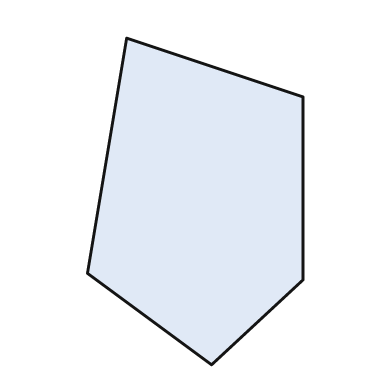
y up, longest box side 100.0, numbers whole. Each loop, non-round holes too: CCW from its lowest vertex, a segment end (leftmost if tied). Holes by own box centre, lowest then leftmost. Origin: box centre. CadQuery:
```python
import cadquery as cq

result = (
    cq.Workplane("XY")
    .moveTo(5.0, -50.0)
    .lineTo(33.0, -24.0)
    .lineTo(33.0, 32.0)
    .lineTo(-21.0, 50.0)
    .lineTo(-33.0, -22.0)
    .close()
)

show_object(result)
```